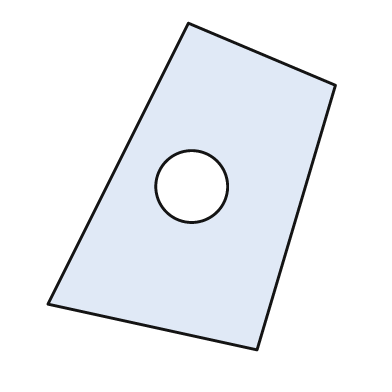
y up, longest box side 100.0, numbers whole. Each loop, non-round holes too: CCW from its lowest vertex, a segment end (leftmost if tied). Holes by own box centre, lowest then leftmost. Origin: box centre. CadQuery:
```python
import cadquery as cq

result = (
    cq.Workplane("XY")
    .moveTo(20.0, -50.0)
    .lineTo(44.0, 31.0)
    .lineTo(-1.0, 50.0)
    .lineTo(-44.0, -36.0)
    .close()
    .moveTo(0.0, 0.0)
    .circle(11.0)
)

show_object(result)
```